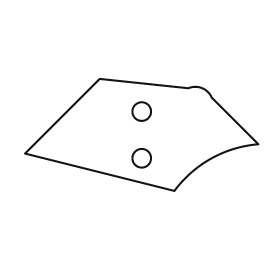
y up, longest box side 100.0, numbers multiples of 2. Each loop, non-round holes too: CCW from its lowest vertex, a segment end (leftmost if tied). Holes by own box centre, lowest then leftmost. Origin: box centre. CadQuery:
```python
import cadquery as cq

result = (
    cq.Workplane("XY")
    .moveTo(14.0, -24.0)
    .threePointArc((30.0, -10.0), (50.0, -4.0))
    .lineTo(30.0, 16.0)
    .threePointArc((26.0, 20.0), (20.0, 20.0))
    .lineTo(-18.0, 24.0)
    .lineTo(-50.0, -8.0)
    .close()
    .moveTo(0.0, -10.0)
    .circle(4.0)
    .moveTo(0.0, 10.0)
    .circle(4.0)
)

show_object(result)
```